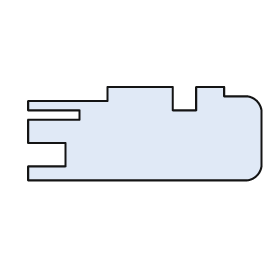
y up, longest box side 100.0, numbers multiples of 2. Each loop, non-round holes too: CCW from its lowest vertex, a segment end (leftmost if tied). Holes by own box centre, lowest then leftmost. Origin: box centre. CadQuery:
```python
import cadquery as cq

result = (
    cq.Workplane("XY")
    .moveTo(-50.0, -20.0)
    .lineTo(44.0, -20.0)
    .threePointArc((48.0, -18.0), (50.0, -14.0))
    .lineTo(50.0, 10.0)
    .threePointArc((48.0, 14.0), (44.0, 16.0))
    .lineTo(34.0, 16.0)
    .lineTo(34.0, 20.0)
    .lineTo(22.0, 20.0)
    .lineTo(22.0, 10.0)
    .lineTo(12.0, 10.0)
    .lineTo(12.0, 20.0)
    .lineTo(-16.0, 20.0)
    .lineTo(-16.0, 14.0)
    .lineTo(-50.0, 14.0)
    .lineTo(-50.0, 10.0)
    .lineTo(-28.0, 10.0)
    .lineTo(-28.0, 6.0)
    .lineTo(-50.0, 6.0)
    .lineTo(-50.0, -4.0)
    .lineTo(-34.0, -4.0)
    .lineTo(-34.0, -14.0)
    .lineTo(-50.0, -14.0)
    .close()
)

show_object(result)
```